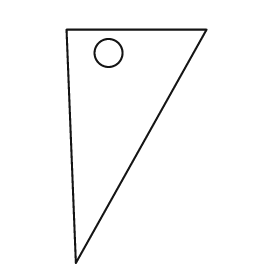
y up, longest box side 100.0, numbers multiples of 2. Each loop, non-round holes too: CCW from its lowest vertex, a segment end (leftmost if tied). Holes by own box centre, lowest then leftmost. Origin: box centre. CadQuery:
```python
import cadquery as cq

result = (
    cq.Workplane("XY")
    .moveTo(-26.0, -50.0)
    .lineTo(30.0, 50.0)
    .lineTo(-30.0, 50.0)
    .close()
    .moveTo(-12.0, 40.0)
    .circle(6.0)
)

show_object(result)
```